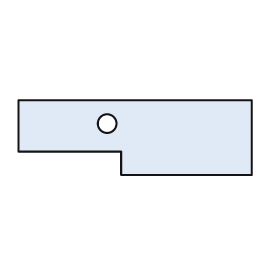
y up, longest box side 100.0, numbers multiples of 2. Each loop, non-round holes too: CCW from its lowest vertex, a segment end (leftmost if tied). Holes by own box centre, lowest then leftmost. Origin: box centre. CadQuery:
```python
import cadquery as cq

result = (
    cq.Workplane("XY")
    .moveTo(-6.0, -16.0)
    .lineTo(50.0, -16.0)
    .lineTo(50.0, 16.0)
    .lineTo(-50.0, 16.0)
    .lineTo(-50.0, -6.0)
    .lineTo(-6.0, -6.0)
    .close()
    .moveTo(-12.0, 6.0)
    .circle(4.0)
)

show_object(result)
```